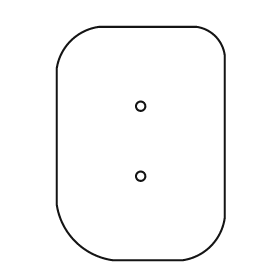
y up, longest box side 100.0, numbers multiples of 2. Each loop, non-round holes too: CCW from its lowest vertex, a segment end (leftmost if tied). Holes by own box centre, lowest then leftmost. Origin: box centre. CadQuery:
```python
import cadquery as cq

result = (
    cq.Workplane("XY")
    .moveTo(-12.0, -50.0)
    .lineTo(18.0, -50.0)
    .threePointArc((30.0, -44.0), (36.0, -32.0))
    .lineTo(36.0, 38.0)
    .threePointArc((32.0, 46.0), (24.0, 50.0))
    .lineTo(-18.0, 50.0)
    .threePointArc((-30.0, 44.0), (-36.0, 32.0))
    .lineTo(-36.0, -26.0)
    .threePointArc((-28.0, -42.0), (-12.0, -50.0))
    .close()
    .moveTo(0.0, -14.0)
    .circle(2.0)
    .moveTo(0.0, 16.0)
    .circle(2.0)
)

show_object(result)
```